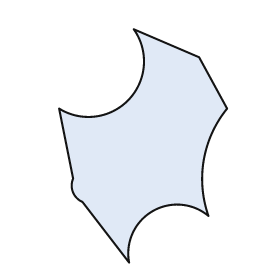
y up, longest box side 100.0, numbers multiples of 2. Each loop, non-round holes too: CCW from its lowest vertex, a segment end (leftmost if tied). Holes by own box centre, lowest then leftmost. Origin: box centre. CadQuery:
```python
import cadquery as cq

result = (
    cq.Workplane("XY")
    .moveTo(-6.0, -50.0)
    .threePointArc((4.0, -28.0), (28.0, -30.0))
    .threePointArc((26.0, -6.0), (36.0, 16.0))
    .lineTo(24.0, 38.0)
    .lineTo(-4.0, 50.0)
    .threePointArc((-6.0, 20.0), (-36.0, 16.0))
    .lineTo(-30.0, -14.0)
    .threePointArc((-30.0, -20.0), (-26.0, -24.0))
    .close()
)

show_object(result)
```